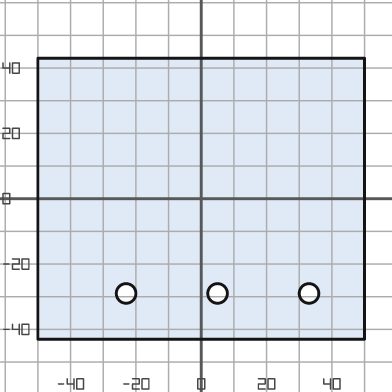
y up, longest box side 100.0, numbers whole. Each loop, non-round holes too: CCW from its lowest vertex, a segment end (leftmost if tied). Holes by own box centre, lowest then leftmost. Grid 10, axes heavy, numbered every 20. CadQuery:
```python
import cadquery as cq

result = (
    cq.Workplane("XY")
    .moveTo(-50.0, -43.0)
    .lineTo(50.0, -43.0)
    .lineTo(50.0, 43.0)
    .lineTo(-50.0, 43.0)
    .close()
    .moveTo(-23.0, -29.0)
    .circle(3.0)
    .moveTo(5.0, -29.0)
    .circle(3.0)
    .moveTo(33.0, -29.0)
    .circle(3.0)
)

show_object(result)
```